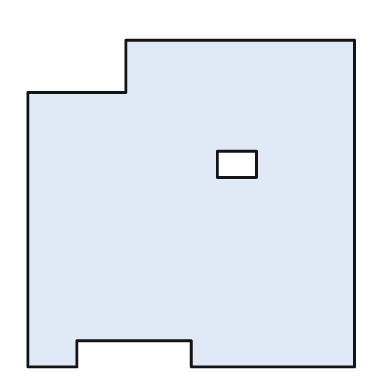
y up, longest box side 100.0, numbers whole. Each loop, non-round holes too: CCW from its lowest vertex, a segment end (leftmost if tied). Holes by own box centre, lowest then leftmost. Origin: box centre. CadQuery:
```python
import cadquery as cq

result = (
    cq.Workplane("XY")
    .moveTo(-50.0, -50.0)
    .lineTo(-35.0, -50.0)
    .lineTo(-35.0, -42.0)
    .lineTo(0.0, -42.0)
    .lineTo(0.0, -50.0)
    .lineTo(50.0, -50.0)
    .lineTo(50.0, 50.0)
    .lineTo(-20.0, 50.0)
    .lineTo(-20.0, 34.0)
    .lineTo(-50.0, 34.0)
    .close()
    .moveTo(8.0, 8.0)
    .lineTo(20.0, 8.0)
    .lineTo(20.0, 16.0)
    .lineTo(8.0, 16.0)
    .close()
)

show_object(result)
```